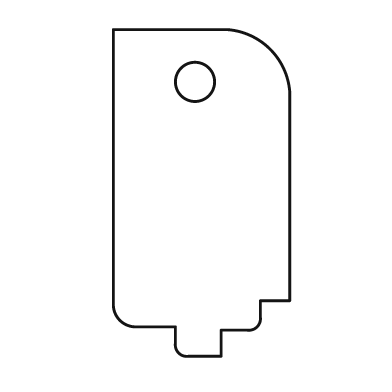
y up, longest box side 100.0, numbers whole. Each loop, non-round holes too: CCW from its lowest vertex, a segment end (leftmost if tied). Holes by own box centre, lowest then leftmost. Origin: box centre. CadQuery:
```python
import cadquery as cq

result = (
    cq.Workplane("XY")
    .moveTo(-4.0, -50.0)
    .lineTo(6.0, -50.0)
    .lineTo(6.0, -42.0)
    .lineTo(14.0, -42.0)
    .threePointArc((17.0, -41.0), (18.0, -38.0))
    .lineTo(18.0, -33.0)
    .lineTo(27.0, -33.0)
    .lineTo(27.0, 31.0)
    .threePointArc((21.0, 44.0), (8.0, 50.0))
    .lineTo(-27.0, 50.0)
    .lineTo(-27.0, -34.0)
    .threePointArc((-25.0, -39.0), (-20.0, -41.0))
    .lineTo(-8.0, -41.0)
    .lineTo(-8.0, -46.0)
    .threePointArc((-7.0, -49.0), (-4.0, -50.0))
    .close()
    .moveTo(-2.0, 34.0)
    .circle(6.0)
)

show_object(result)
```